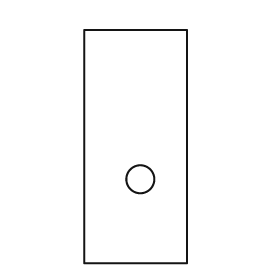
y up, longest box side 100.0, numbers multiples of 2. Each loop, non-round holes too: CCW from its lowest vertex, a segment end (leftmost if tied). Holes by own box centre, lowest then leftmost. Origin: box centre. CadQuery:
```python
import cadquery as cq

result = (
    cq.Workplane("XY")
    .moveTo(-22.0, -50.0)
    .lineTo(22.0, -50.0)
    .lineTo(22.0, 50.0)
    .lineTo(-22.0, 50.0)
    .close()
    .moveTo(2.0, -14.0)
    .circle(6.0)
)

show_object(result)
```